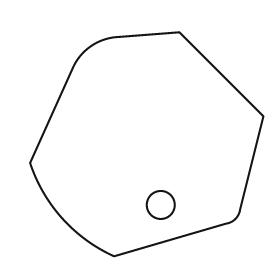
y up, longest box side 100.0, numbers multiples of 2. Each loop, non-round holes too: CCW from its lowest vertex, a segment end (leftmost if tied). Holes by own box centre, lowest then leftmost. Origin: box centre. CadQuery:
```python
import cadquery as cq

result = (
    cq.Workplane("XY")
    .moveTo(-14.0, -48.0)
    .lineTo(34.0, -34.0)
    .threePointArc((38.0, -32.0), (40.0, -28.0))
    .lineTo(50.0, 12.0)
    .lineTo(14.0, 48.0)
    .lineTo(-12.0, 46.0)
    .threePointArc((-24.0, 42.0), (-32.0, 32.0))
    .lineTo(-50.0, -8.0)
    .threePointArc((-36.0, -32.0), (-14.0, -48.0))
    .close()
    .moveTo(6.0, -26.0)
    .circle(6.0)
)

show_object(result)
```